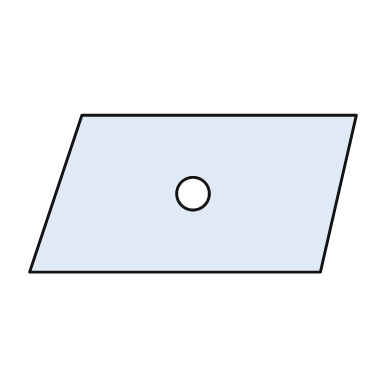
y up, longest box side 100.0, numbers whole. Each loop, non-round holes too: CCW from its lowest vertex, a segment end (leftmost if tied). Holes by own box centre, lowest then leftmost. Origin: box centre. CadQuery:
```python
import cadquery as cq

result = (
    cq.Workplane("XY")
    .moveTo(-50.0, -24.0)
    .lineTo(39.0, -24.0)
    .lineTo(50.0, 24.0)
    .lineTo(-34.0, 24.0)
    .close()
    .moveTo(0.0, 0.0)
    .circle(5.0)
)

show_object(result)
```